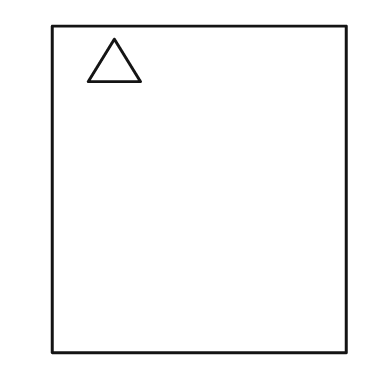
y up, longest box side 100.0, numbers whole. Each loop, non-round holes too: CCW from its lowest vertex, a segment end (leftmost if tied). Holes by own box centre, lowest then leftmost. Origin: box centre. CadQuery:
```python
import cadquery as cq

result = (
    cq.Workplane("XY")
    .moveTo(-45.0, -50.0)
    .lineTo(45.0, -50.0)
    .lineTo(45.0, 50.0)
    .lineTo(-45.0, 50.0)
    .close()
    .moveTo(-34.0, 33.0)
    .lineTo(-18.0, 33.0)
    .lineTo(-26.0, 46.0)
    .close()
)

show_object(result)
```